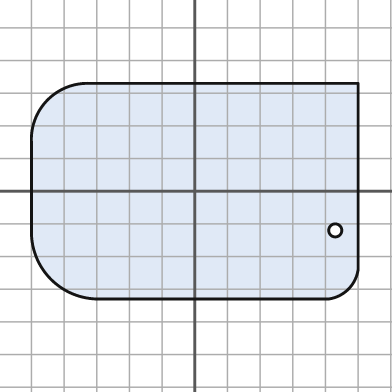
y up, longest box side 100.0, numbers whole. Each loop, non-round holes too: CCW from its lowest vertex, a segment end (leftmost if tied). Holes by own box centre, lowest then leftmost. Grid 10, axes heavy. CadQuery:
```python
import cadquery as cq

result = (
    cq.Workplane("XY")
    .moveTo(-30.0, -33.0)
    .lineTo(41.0, -33.0)
    .threePointArc((47.0, -30.0), (50.0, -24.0))
    .lineTo(50.0, 33.0)
    .lineTo(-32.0, 33.0)
    .threePointArc((-45.0, 28.0), (-50.0, 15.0))
    .lineTo(-50.0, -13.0)
    .threePointArc((-44.0, -27.0), (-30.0, -33.0))
    .close()
    .moveTo(43.0, -12.0)
    .circle(2.0)
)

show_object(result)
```